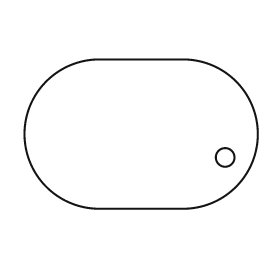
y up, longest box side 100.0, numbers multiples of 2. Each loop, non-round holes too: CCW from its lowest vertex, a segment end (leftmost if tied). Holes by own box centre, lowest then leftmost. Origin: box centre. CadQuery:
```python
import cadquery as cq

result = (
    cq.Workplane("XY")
    .moveTo(-18.0, -32.0)
    .lineTo(18.0, -32.0)
    .threePointArc((50.0, 0.0), (18.0, 32.0))
    .lineTo(-18.0, 32.0)
    .threePointArc((-50.0, 0.0), (-18.0, -32.0))
    .close()
    .moveTo(36.0, -10.0)
    .circle(4.0)
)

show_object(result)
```